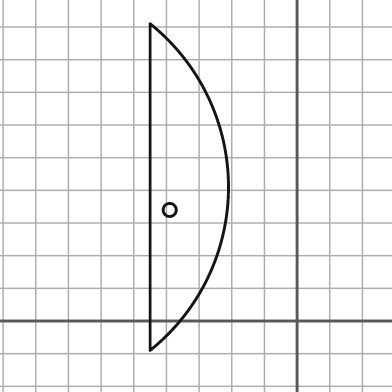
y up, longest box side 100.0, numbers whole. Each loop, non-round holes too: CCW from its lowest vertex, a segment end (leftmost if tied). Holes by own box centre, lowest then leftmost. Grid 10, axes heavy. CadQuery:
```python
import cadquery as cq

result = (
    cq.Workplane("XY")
    .moveTo(-45.0, -9.0)
    .threePointArc((-21.0, 41.0), (-45.0, 91.0))
    .close()
    .moveTo(-39.0, 34.0)
    .circle(2.0)
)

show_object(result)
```